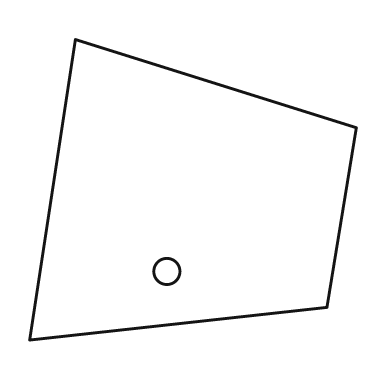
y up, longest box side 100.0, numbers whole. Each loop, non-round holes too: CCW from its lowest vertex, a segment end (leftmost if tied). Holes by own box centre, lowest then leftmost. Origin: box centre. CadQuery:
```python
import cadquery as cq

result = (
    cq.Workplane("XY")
    .moveTo(-50.0, -46.0)
    .lineTo(41.0, -36.0)
    .lineTo(50.0, 19.0)
    .lineTo(-36.0, 46.0)
    .close()
    .moveTo(-8.0, -25.0)
    .circle(4.0)
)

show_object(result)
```